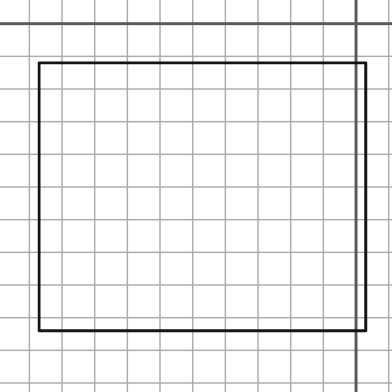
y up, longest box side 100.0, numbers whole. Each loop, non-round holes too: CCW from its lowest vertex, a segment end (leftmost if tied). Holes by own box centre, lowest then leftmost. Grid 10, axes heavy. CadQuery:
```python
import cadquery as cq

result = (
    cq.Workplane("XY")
    .moveTo(-97.0, -94.0)
    .lineTo(3.0, -94.0)
    .lineTo(3.0, -12.0)
    .lineTo(-97.0, -12.0)
    .close()
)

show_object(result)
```